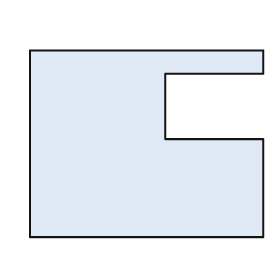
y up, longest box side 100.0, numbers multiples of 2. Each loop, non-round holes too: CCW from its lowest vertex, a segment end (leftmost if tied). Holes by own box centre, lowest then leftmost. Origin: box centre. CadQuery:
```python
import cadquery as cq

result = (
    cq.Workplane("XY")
    .moveTo(-50.0, -40.0)
    .lineTo(50.0, -40.0)
    .lineTo(50.0, 2.0)
    .lineTo(8.0, 2.0)
    .lineTo(8.0, 30.0)
    .lineTo(50.0, 30.0)
    .lineTo(50.0, 40.0)
    .lineTo(-50.0, 40.0)
    .close()
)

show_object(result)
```